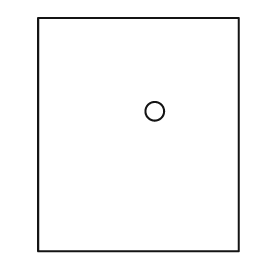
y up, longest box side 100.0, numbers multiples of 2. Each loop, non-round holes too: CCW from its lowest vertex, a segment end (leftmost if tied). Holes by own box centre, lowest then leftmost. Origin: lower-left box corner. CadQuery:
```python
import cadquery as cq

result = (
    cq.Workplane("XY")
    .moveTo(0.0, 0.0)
    .lineTo(86.0, 0.0)
    .lineTo(86.0, 100.0)
    .lineTo(0.0, 100.0)
    .close()
    .moveTo(50.0, 60.0)
    .circle(4.0)
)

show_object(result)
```